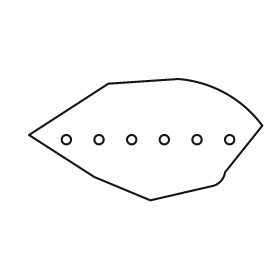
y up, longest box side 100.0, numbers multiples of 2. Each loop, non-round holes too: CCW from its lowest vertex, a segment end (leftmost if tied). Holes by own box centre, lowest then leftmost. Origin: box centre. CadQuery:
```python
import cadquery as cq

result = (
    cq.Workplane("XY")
    .moveTo(2.0, -26.0)
    .lineTo(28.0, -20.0)
    .threePointArc((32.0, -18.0), (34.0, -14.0))
    .lineTo(50.0, 6.0)
    .threePointArc((34.0, 20.0), (14.0, 26.0))
    .lineTo(-16.0, 24.0)
    .lineTo(-50.0, 2.0)
    .lineTo(-22.0, -16.0)
    .close()
    .moveTo(-34.0, 0.0)
    .circle(2.0)
    .moveTo(-20.0, 0.0)
    .circle(2.0)
    .moveTo(-6.0, 0.0)
    .circle(2.0)
    .moveTo(8.0, 0.0)
    .circle(2.0)
    .moveTo(22.0, 0.0)
    .circle(2.0)
    .moveTo(36.0, 0.0)
    .circle(2.0)
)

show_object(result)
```